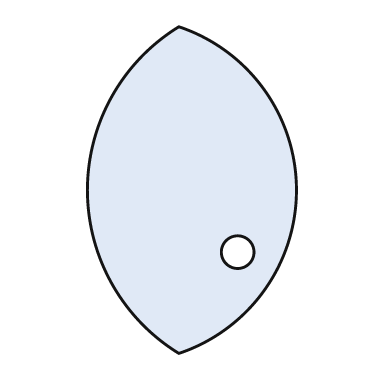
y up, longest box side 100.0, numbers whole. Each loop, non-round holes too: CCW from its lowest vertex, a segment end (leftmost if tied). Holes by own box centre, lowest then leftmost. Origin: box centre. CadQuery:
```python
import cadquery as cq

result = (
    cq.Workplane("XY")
    .moveTo(-4.0, -50.0)
    .threePointArc((32.0, 0.0), (-4.0, 50.0))
    .threePointArc((-32.0, 0.0), (-4.0, -50.0))
    .close()
    .moveTo(14.0, -19.0)
    .circle(5.0)
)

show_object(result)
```